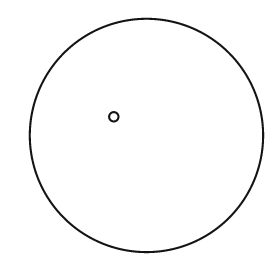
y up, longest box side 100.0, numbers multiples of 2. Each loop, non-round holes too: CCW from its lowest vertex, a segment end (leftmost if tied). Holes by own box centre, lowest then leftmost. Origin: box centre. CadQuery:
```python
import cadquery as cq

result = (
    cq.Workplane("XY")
    .moveTo(0.0, 0.0)
    .circle(50.0)
    .moveTo(-14.0, 8.0)
    .circle(2.0)
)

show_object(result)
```